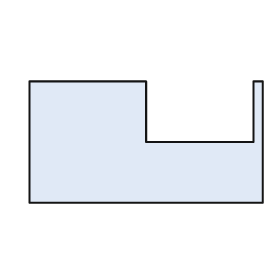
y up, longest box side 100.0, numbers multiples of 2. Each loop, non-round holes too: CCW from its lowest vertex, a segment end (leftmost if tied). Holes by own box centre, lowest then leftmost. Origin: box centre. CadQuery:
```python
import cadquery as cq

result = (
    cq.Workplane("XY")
    .moveTo(-50.0, -26.0)
    .lineTo(50.0, -26.0)
    .lineTo(50.0, 26.0)
    .lineTo(46.0, 26.0)
    .lineTo(46.0, 0.0)
    .lineTo(0.0, 0.0)
    .lineTo(0.0, 26.0)
    .lineTo(-50.0, 26.0)
    .close()
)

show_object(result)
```